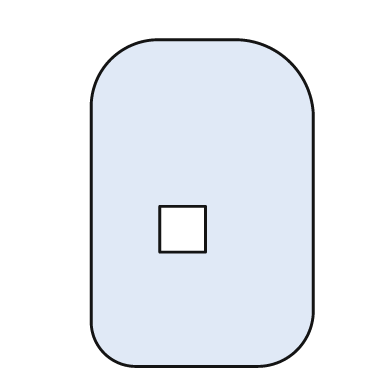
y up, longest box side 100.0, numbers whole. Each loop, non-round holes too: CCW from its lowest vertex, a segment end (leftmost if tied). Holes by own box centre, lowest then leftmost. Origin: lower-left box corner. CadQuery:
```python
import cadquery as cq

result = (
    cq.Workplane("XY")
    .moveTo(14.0, 0.0)
    .lineTo(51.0, 0.0)
    .threePointArc((63.0, 5.0), (68.0, 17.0))
    .lineTo(68.0, 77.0)
    .threePointArc((61.0, 93.0), (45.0, 100.0))
    .lineTo(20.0, 100.0)
    .threePointArc((6.0, 94.0), (0.0, 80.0))
    .lineTo(0.0, 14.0)
    .threePointArc((4.0, 4.0), (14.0, 0.0))
    .close()
    .moveTo(21.0, 35.0)
    .lineTo(35.0, 35.0)
    .lineTo(35.0, 49.0)
    .lineTo(21.0, 49.0)
    .close()
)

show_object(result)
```